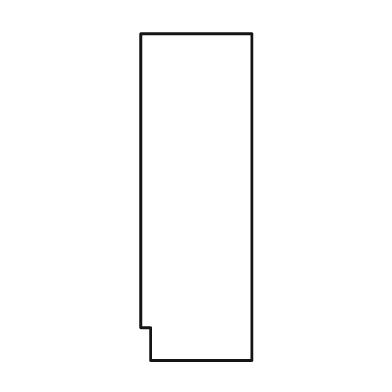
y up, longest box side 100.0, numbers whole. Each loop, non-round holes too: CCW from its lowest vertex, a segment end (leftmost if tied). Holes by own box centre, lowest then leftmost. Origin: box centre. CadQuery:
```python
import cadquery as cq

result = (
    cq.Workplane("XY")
    .moveTo(-14.0, -50.0)
    .lineTo(17.0, -50.0)
    .lineTo(17.0, 50.0)
    .lineTo(-17.0, 50.0)
    .lineTo(-17.0, -40.0)
    .lineTo(-14.0, -40.0)
    .close()
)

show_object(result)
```